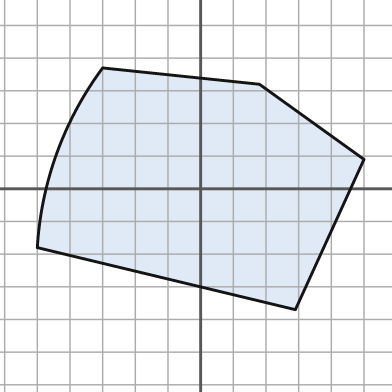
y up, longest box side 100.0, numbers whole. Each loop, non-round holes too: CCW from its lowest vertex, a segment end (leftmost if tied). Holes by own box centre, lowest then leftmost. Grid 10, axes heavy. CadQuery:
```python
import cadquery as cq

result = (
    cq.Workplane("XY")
    .moveTo(29.0, -37.0)
    .lineTo(50.0, 9.0)
    .lineTo(18.0, 32.0)
    .lineTo(-30.0, 37.0)
    .threePointArc((-44.0, 11.0), (-50.0, -18.0))
    .close()
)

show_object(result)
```